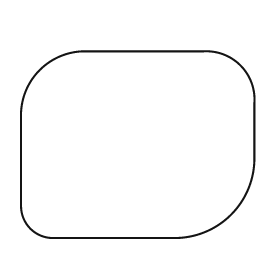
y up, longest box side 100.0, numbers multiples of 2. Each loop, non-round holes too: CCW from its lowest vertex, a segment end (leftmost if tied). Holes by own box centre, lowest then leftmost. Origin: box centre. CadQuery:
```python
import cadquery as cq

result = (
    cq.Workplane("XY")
    .moveTo(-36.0, -40.0)
    .lineTo(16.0, -40.0)
    .threePointArc((40.0, -30.0), (50.0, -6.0))
    .lineTo(50.0, 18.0)
    .threePointArc((44.0, 34.0), (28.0, 40.0))
    .lineTo(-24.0, 40.0)
    .threePointArc((-42.0, 32.0), (-50.0, 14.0))
    .lineTo(-50.0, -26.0)
    .threePointArc((-46.0, -36.0), (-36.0, -40.0))
    .close()
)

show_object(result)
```